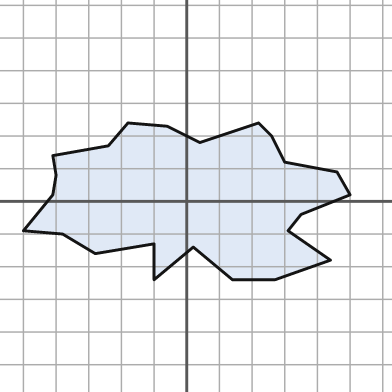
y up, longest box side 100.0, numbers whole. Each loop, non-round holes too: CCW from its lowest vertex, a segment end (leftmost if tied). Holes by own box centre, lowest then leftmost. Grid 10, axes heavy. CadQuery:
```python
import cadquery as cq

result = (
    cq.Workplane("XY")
    .moveTo(-10.0, -24.0)
    .lineTo(2.0, -14.0)
    .lineTo(14.0, -24.0)
    .lineTo(27.0, -24.0)
    .lineTo(44.0, -18.0)
    .lineTo(31.0, -9.0)
    .lineTo(35.0, -4.0)
    .lineTo(50.0, 2.0)
    .lineTo(46.0, 9.0)
    .lineTo(30.0, 12.0)
    .lineTo(26.0, 20.0)
    .lineTo(22.0, 24.0)
    .lineTo(4.0, 18.0)
    .lineTo(-6.0, 23.0)
    .lineTo(-18.0, 24.0)
    .lineTo(-24.0, 17.0)
    .lineTo(-41.0, 14.0)
    .lineTo(-40.0, 8.0)
    .lineTo(-41.0, 2.0)
    .lineTo(-50.0, -9.0)
    .lineTo(-38.0, -10.0)
    .lineTo(-28.0, -16.0)
    .lineTo(-10.0, -13.0)
    .close()
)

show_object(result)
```